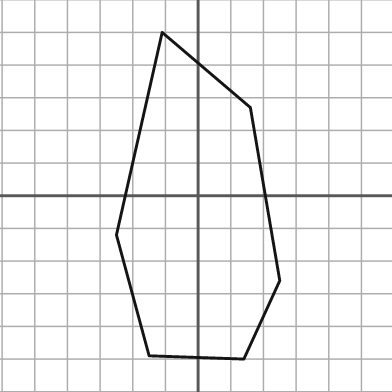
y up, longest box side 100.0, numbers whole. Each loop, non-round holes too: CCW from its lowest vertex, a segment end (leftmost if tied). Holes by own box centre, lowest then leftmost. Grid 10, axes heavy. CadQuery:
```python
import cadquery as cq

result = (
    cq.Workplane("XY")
    .moveTo(14.0, -50.0)
    .lineTo(25.0, -26.0)
    .lineTo(16.0, 27.0)
    .lineTo(-11.0, 50.0)
    .lineTo(-25.0, -12.0)
    .lineTo(-15.0, -49.0)
    .close()
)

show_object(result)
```